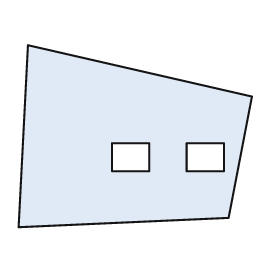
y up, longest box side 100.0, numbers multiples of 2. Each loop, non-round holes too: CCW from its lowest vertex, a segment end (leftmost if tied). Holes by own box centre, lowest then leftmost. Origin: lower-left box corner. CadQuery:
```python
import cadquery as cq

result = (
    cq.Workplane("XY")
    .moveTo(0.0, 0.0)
    .lineTo(90.0, 4.0)
    .lineTo(100.0, 56.0)
    .lineTo(4.0, 78.0)
    .close()
    .moveTo(40.0, 24.0)
    .lineTo(56.0, 24.0)
    .lineTo(56.0, 36.0)
    .lineTo(40.0, 36.0)
    .close()
    .moveTo(72.0, 24.0)
    .lineTo(88.0, 24.0)
    .lineTo(88.0, 36.0)
    .lineTo(72.0, 36.0)
    .close()
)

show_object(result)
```